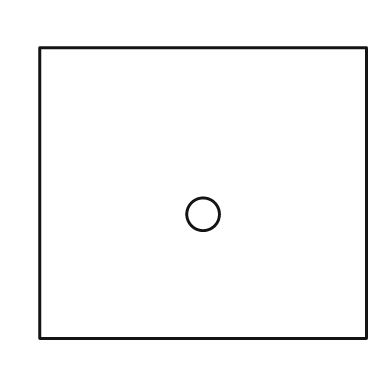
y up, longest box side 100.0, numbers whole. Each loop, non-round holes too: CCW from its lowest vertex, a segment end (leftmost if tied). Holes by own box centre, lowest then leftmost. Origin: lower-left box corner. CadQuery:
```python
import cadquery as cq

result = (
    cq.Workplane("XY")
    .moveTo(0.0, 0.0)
    .lineTo(100.0, 0.0)
    .lineTo(100.0, 89.0)
    .lineTo(0.0, 89.0)
    .close()
    .moveTo(50.0, 38.0)
    .circle(5.0)
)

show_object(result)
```